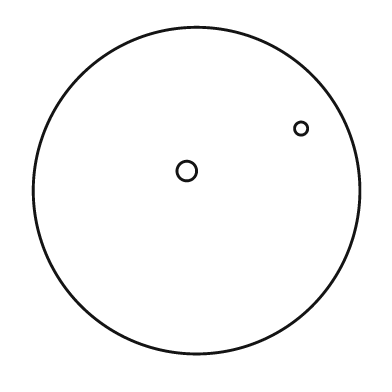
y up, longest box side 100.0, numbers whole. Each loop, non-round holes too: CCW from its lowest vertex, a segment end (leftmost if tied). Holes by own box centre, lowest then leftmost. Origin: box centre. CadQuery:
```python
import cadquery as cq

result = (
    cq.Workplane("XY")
    .moveTo(0.0, 0.0)
    .circle(50.0)
    .moveTo(-3.0, 6.0)
    .circle(3.0)
    .moveTo(32.0, 19.0)
    .circle(2.0)
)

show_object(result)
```